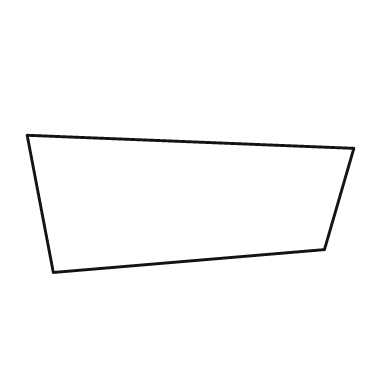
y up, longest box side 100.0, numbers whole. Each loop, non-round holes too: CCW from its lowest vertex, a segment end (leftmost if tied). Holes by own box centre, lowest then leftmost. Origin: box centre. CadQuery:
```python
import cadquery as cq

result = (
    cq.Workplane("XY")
    .moveTo(-42.0, -21.0)
    .lineTo(41.0, -14.0)
    .lineTo(50.0, 17.0)
    .lineTo(-50.0, 21.0)
    .close()
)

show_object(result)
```